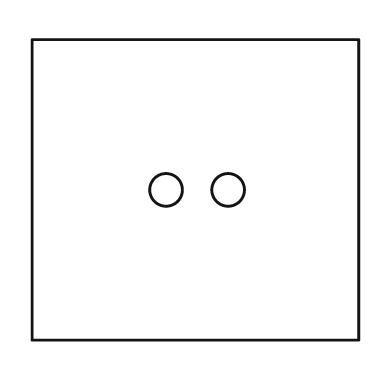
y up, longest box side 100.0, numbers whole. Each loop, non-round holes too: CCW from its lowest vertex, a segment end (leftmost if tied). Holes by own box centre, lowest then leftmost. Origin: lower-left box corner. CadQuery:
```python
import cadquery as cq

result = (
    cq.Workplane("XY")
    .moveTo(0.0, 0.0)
    .lineTo(100.0, 0.0)
    .lineTo(100.0, 92.0)
    .lineTo(0.0, 92.0)
    .close()
    .moveTo(41.0, 46.0)
    .circle(5.0)
    .moveTo(60.0, 46.0)
    .circle(5.0)
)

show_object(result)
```